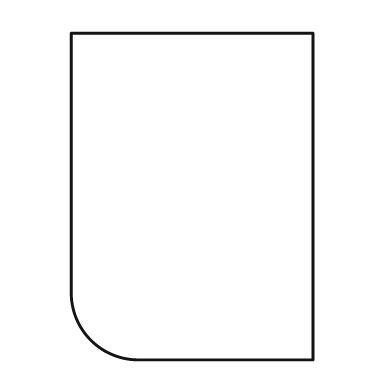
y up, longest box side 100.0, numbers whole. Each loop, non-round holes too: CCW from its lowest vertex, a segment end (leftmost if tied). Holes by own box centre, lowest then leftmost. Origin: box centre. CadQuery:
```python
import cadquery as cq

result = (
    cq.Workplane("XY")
    .moveTo(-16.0, -50.0)
    .lineTo(37.0, -50.0)
    .lineTo(37.0, 50.0)
    .lineTo(-37.0, 50.0)
    .lineTo(-37.0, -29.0)
    .threePointArc((-31.0, -44.0), (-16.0, -50.0))
    .close()
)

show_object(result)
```